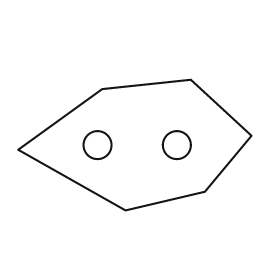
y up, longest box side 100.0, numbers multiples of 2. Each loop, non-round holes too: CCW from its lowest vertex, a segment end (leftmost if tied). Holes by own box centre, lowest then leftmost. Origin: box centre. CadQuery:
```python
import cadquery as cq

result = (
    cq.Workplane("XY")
    .moveTo(-4.0, -28.0)
    .lineTo(30.0, -20.0)
    .lineTo(50.0, 4.0)
    .lineTo(24.0, 28.0)
    .lineTo(-14.0, 24.0)
    .lineTo(-50.0, -2.0)
    .close()
    .moveTo(-16.0, 0.0)
    .circle(6.0)
    .moveTo(18.0, 0.0)
    .circle(6.0)
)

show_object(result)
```